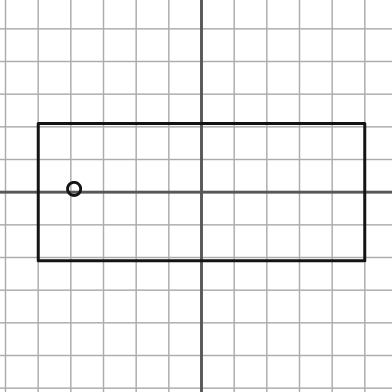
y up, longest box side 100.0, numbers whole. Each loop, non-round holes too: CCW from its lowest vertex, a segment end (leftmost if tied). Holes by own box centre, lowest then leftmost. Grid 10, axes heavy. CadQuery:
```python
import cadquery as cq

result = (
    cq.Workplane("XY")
    .moveTo(-50.0, -21.0)
    .lineTo(50.0, -21.0)
    .lineTo(50.0, 21.0)
    .lineTo(-50.0, 21.0)
    .close()
    .moveTo(-39.0, 1.0)
    .circle(2.0)
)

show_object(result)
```